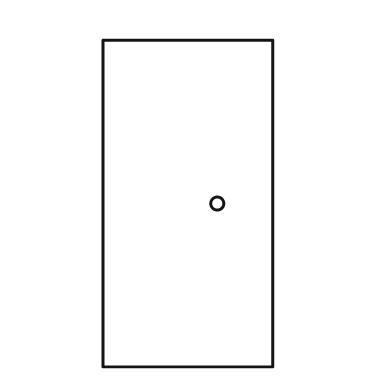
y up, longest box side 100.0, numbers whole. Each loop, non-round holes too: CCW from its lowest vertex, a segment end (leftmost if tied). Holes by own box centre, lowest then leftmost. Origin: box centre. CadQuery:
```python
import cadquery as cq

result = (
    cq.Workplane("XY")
    .moveTo(-26.0, -50.0)
    .lineTo(26.0, -50.0)
    .lineTo(26.0, 50.0)
    .lineTo(-26.0, 50.0)
    .close()
    .moveTo(9.0, 0.0)
    .circle(2.0)
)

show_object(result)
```